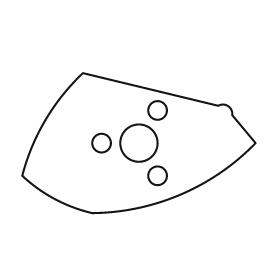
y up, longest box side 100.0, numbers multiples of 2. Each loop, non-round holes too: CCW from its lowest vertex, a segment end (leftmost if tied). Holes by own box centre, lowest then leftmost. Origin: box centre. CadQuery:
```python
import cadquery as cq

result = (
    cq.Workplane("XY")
    .moveTo(-20.0, -30.0)
    .threePointArc((18.0, -22.0), (50.0, 0.0))
    .lineTo(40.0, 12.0)
    .threePointArc((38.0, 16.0), (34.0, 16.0))
    .lineTo(-24.0, 30.0)
    .threePointArc((-40.0, 10.0), (-50.0, -14.0))
    .threePointArc((-36.0, -24.0), (-20.0, -30.0))
    .close()
    .moveTo(8.0, -14.0)
    .circle(4.0)
    .moveTo(-16.0, 0.0)
    .circle(4.0)
    .moveTo(0.0, 0.0)
    .circle(8.0)
    .moveTo(8.0, 14.0)
    .circle(4.0)
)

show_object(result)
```